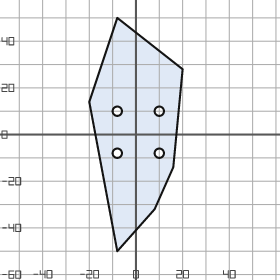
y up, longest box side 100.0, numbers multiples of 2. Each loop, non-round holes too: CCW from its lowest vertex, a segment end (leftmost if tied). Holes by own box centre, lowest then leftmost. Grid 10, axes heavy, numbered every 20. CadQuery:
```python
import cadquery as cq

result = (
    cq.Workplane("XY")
    .moveTo(-8.0, -50.0)
    .lineTo(8.0, -32.0)
    .lineTo(16.0, -14.0)
    .lineTo(20.0, 28.0)
    .lineTo(-8.0, 50.0)
    .lineTo(-20.0, 14.0)
    .close()
    .moveTo(-8.0, -8.0)
    .circle(2.0)
    .moveTo(10.0, -8.0)
    .circle(2.0)
    .moveTo(-8.0, 10.0)
    .circle(2.0)
    .moveTo(10.0, 10.0)
    .circle(2.0)
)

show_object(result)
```